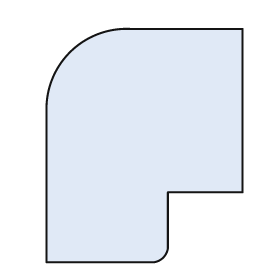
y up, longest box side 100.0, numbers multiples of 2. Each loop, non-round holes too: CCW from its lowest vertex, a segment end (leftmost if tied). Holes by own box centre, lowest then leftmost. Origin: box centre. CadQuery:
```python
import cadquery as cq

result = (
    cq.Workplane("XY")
    .moveTo(-42.0, -50.0)
    .lineTo(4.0, -50.0)
    .threePointArc((8.0, -48.0), (10.0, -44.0))
    .lineTo(10.0, -20.0)
    .lineTo(42.0, -20.0)
    .lineTo(42.0, 50.0)
    .lineTo(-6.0, 50.0)
    .threePointArc((-32.0, 40.0), (-42.0, 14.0))
    .close()
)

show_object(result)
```